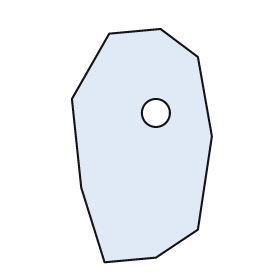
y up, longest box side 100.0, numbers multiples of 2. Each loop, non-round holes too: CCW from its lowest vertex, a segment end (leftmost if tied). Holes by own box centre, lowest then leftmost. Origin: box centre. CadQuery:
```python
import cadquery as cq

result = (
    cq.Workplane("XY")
    .moveTo(-16.0, -50.0)
    .lineTo(6.0, -48.0)
    .lineTo(24.0, -36.0)
    .lineTo(30.0, 4.0)
    .lineTo(24.0, 38.0)
    .lineTo(8.0, 50.0)
    .lineTo(-14.0, 48.0)
    .lineTo(-30.0, 20.0)
    .lineTo(-26.0, -18.0)
    .close()
    .moveTo(6.0, 14.0)
    .circle(6.0)
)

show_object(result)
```